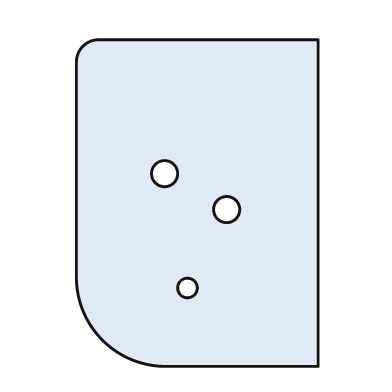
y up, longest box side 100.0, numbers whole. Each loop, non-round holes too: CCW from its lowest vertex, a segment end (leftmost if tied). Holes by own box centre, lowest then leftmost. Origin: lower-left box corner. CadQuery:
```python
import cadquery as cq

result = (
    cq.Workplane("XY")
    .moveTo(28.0, 0.0)
    .lineTo(74.0, 0.0)
    .lineTo(74.0, 100.0)
    .lineTo(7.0, 100.0)
    .threePointArc((2.0, 98.0), (0.0, 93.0))
    .lineTo(0.0, 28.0)
    .threePointArc((8.0, 8.0), (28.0, 0.0))
    .close()
    .moveTo(34.0, 24.0)
    .circle(3.0)
    .moveTo(46.0, 48.0)
    .circle(4.0)
    .moveTo(27.0, 59.0)
    .circle(4.0)
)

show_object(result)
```